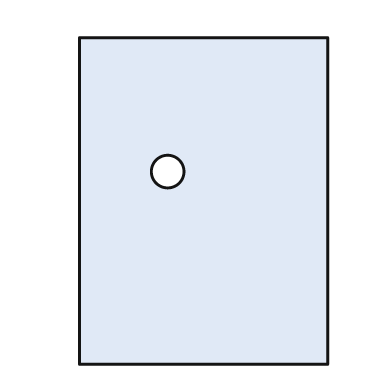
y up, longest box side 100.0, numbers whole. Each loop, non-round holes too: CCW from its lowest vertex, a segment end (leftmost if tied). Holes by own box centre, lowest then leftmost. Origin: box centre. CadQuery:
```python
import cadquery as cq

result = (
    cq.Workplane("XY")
    .moveTo(-38.0, -50.0)
    .lineTo(38.0, -50.0)
    .lineTo(38.0, 50.0)
    .lineTo(-38.0, 50.0)
    .close()
    .moveTo(-11.0, 9.0)
    .circle(5.0)
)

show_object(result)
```